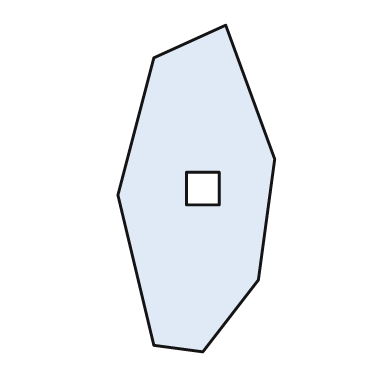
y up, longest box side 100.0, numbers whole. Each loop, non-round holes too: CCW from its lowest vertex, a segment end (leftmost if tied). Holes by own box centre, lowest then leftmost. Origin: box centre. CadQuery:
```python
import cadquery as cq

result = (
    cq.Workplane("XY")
    .moveTo(2.0, -50.0)
    .lineTo(19.0, -28.0)
    .lineTo(24.0, 9.0)
    .lineTo(9.0, 50.0)
    .lineTo(-13.0, 40.0)
    .lineTo(-24.0, -2.0)
    .lineTo(-13.0, -48.0)
    .close()
    .moveTo(-3.0, -5.0)
    .lineTo(7.0, -5.0)
    .lineTo(7.0, 5.0)
    .lineTo(-3.0, 5.0)
    .close()
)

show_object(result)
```